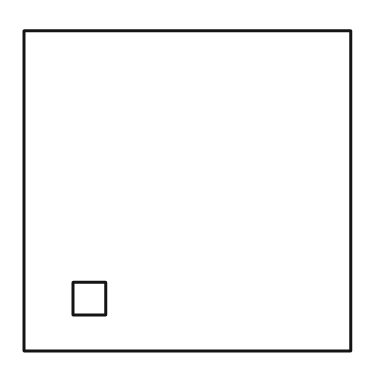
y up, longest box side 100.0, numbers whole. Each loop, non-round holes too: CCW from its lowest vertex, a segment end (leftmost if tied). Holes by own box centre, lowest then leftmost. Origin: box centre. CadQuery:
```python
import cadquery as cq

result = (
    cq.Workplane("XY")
    .moveTo(-50.0, -49.0)
    .lineTo(50.0, -49.0)
    .lineTo(50.0, 49.0)
    .lineTo(-50.0, 49.0)
    .close()
    .moveTo(-35.0, -38.0)
    .lineTo(-25.0, -38.0)
    .lineTo(-25.0, -28.0)
    .lineTo(-35.0, -28.0)
    .close()
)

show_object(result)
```